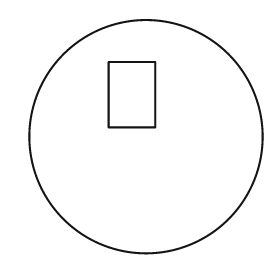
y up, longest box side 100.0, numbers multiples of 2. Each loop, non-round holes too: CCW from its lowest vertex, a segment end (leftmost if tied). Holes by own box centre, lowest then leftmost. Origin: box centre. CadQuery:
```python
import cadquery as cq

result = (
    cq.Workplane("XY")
    .moveTo(0.0, 0.0)
    .circle(50.0)
    .moveTo(-16.0, 4.0)
    .lineTo(4.0, 4.0)
    .lineTo(4.0, 32.0)
    .lineTo(-16.0, 32.0)
    .close()
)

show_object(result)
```